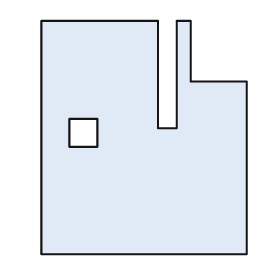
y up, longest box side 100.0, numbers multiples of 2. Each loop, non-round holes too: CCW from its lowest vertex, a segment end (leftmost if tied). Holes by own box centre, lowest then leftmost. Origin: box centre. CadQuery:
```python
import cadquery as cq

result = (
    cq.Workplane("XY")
    .moveTo(-44.0, -50.0)
    .lineTo(44.0, -50.0)
    .lineTo(44.0, 24.0)
    .lineTo(20.0, 24.0)
    .lineTo(20.0, 50.0)
    .lineTo(14.0, 50.0)
    .lineTo(14.0, 4.0)
    .lineTo(6.0, 4.0)
    .lineTo(6.0, 50.0)
    .lineTo(-44.0, 50.0)
    .close()
    .moveTo(-32.0, -4.0)
    .lineTo(-20.0, -4.0)
    .lineTo(-20.0, 8.0)
    .lineTo(-32.0, 8.0)
    .close()
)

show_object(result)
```